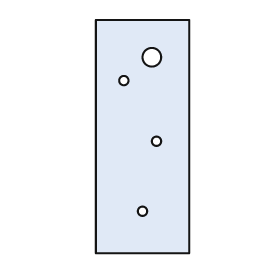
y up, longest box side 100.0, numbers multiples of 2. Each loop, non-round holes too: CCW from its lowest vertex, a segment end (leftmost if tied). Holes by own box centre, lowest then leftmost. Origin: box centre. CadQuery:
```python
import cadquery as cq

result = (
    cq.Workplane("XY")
    .moveTo(-20.0, -50.0)
    .lineTo(20.0, -50.0)
    .lineTo(20.0, 50.0)
    .lineTo(-20.0, 50.0)
    .close()
    .moveTo(0.0, -32.0)
    .circle(2.0)
    .moveTo(6.0, -2.0)
    .circle(2.0)
    .moveTo(-8.0, 24.0)
    .circle(2.0)
    .moveTo(4.0, 34.0)
    .circle(4.0)
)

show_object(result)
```